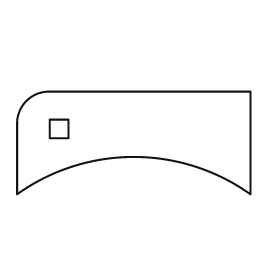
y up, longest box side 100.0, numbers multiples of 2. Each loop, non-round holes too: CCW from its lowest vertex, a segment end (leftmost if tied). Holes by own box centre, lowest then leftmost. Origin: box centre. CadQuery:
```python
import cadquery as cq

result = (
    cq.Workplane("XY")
    .moveTo(-50.0, -22.0)
    .threePointArc((0.0, -6.0), (50.0, -22.0))
    .lineTo(50.0, 22.0)
    .lineTo(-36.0, 22.0)
    .threePointArc((-46.0, 18.0), (-50.0, 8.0))
    .close()
    .moveTo(-36.0, 2.0)
    .lineTo(-28.0, 2.0)
    .lineTo(-28.0, 10.0)
    .lineTo(-36.0, 10.0)
    .close()
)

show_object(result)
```